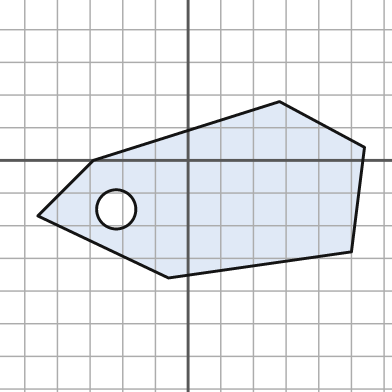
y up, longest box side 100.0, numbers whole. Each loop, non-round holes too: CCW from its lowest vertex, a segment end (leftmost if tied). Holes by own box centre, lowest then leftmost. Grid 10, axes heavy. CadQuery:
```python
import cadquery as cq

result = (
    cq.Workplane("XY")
    .moveTo(-6.0, -36.0)
    .lineTo(50.0, -28.0)
    .lineTo(54.0, 4.0)
    .lineTo(28.0, 18.0)
    .lineTo(-29.0, 0.0)
    .lineTo(-46.0, -17.0)
    .close()
    .moveTo(-22.0, -15.0)
    .circle(6.0)
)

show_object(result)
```